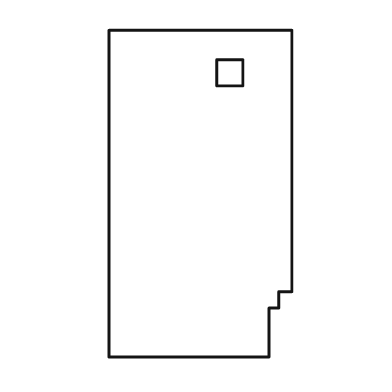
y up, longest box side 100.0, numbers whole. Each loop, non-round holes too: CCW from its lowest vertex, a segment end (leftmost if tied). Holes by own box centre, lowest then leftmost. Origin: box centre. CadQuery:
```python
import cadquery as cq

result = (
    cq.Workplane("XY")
    .moveTo(-28.0, -50.0)
    .lineTo(21.0, -50.0)
    .lineTo(21.0, -35.0)
    .lineTo(24.0, -35.0)
    .lineTo(24.0, -30.0)
    .lineTo(28.0, -30.0)
    .lineTo(28.0, 50.0)
    .lineTo(-28.0, 50.0)
    .close()
    .moveTo(5.0, 33.0)
    .lineTo(13.0, 33.0)
    .lineTo(13.0, 41.0)
    .lineTo(5.0, 41.0)
    .close()
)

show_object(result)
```